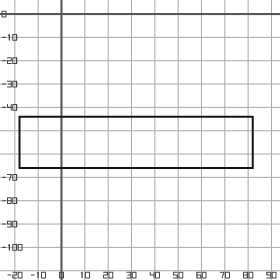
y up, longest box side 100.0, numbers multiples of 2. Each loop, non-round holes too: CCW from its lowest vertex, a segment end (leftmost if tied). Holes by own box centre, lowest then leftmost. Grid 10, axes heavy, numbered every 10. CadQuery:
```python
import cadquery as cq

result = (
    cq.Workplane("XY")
    .moveTo(-18.0, -66.0)
    .lineTo(82.0, -66.0)
    .lineTo(82.0, -44.0)
    .lineTo(-18.0, -44.0)
    .close()
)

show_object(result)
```